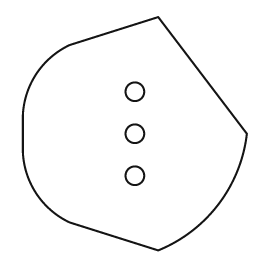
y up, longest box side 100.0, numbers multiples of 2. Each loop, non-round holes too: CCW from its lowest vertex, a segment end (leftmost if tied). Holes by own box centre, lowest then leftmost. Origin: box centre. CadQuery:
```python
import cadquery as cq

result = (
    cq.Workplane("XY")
    .moveTo(10.0, -50.0)
    .threePointArc((36.0, -30.0), (48.0, 0.0))
    .lineTo(10.0, 50.0)
    .lineTo(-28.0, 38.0)
    .threePointArc((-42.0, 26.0), (-48.0, 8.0))
    .lineTo(-48.0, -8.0)
    .threePointArc((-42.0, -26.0), (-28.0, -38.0))
    .close()
    .moveTo(0.0, -18.0)
    .circle(4.0)
    .moveTo(0.0, 0.0)
    .circle(4.0)
    .moveTo(0.0, 18.0)
    .circle(4.0)
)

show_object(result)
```